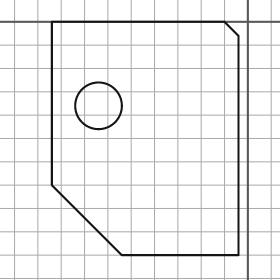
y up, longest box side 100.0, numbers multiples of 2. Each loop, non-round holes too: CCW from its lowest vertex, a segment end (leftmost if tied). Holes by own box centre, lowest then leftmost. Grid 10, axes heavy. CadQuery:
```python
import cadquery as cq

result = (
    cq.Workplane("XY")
    .moveTo(-54.0, -100.0)
    .lineTo(-4.0, -100.0)
    .lineTo(-4.0, -6.0)
    .lineTo(-10.0, 0.0)
    .lineTo(-84.0, 0.0)
    .lineTo(-84.0, -70.0)
    .close()
    .moveTo(-64.0, -36.0)
    .circle(10.0)
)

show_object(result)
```